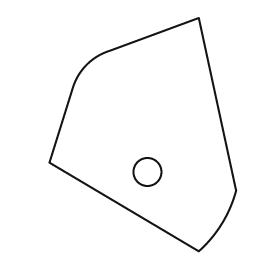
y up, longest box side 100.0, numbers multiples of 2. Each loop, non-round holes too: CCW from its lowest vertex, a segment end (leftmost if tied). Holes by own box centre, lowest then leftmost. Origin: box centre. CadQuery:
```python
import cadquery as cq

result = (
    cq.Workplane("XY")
    .moveTo(24.0, -50.0)
    .threePointArc((34.0, -38.0), (40.0, -24.0))
    .lineTo(24.0, 50.0)
    .lineTo(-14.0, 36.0)
    .threePointArc((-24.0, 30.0), (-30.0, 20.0))
    .lineTo(-40.0, -12.0)
    .close()
    .moveTo(2.0, -16.0)
    .circle(6.0)
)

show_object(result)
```